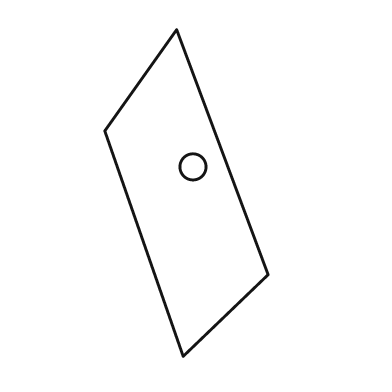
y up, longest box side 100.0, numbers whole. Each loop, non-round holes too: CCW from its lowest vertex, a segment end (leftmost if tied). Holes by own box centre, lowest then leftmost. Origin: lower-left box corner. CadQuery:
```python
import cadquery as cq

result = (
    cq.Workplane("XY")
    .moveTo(24.0, 0.0)
    .lineTo(50.0, 25.0)
    .lineTo(22.0, 100.0)
    .lineTo(0.0, 69.0)
    .close()
    .moveTo(27.0, 58.0)
    .circle(4.0)
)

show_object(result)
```